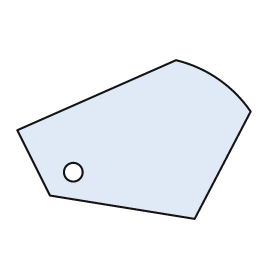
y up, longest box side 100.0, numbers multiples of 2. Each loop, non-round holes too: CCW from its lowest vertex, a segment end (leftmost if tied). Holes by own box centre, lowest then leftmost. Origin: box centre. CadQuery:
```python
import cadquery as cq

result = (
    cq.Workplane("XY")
    .moveTo(26.0, -34.0)
    .lineTo(50.0, 12.0)
    .threePointArc((36.0, 26.0), (18.0, 34.0))
    .lineTo(-50.0, 4.0)
    .lineTo(-36.0, -24.0)
    .close()
    .moveTo(-26.0, -14.0)
    .circle(4.0)
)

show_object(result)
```